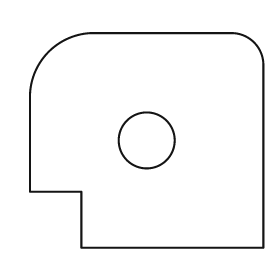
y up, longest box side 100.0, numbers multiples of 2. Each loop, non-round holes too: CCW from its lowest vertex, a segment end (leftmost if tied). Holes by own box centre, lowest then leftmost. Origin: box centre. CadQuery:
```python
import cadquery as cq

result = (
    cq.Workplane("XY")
    .moveTo(-28.0, -46.0)
    .lineTo(50.0, -46.0)
    .lineTo(50.0, 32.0)
    .threePointArc((46.0, 42.0), (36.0, 46.0))
    .lineTo(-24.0, 46.0)
    .threePointArc((-42.0, 38.0), (-50.0, 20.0))
    .lineTo(-50.0, -22.0)
    .lineTo(-28.0, -22.0)
    .close()
    .moveTo(0.0, 0.0)
    .circle(12.0)
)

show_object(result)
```